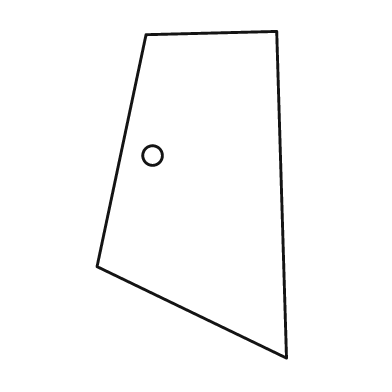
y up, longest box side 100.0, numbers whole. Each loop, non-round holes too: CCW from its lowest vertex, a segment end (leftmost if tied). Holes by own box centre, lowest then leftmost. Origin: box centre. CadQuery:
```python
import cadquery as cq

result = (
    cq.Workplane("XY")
    .moveTo(29.0, -50.0)
    .lineTo(26.0, 50.0)
    .lineTo(-14.0, 49.0)
    .lineTo(-29.0, -22.0)
    .close()
    .moveTo(-12.0, 12.0)
    .circle(3.0)
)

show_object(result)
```